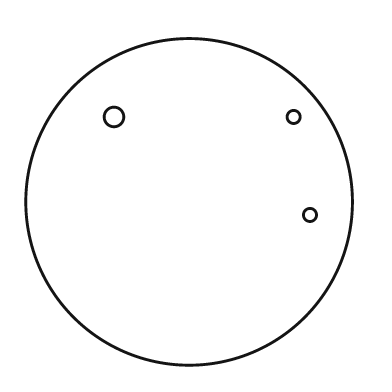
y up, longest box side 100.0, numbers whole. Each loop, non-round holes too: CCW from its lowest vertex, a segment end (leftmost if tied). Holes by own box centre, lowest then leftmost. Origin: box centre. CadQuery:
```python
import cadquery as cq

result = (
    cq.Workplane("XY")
    .moveTo(0.0, 0.0)
    .circle(50.0)
    .moveTo(37.0, -4.0)
    .circle(2.0)
    .moveTo(-23.0, 26.0)
    .circle(3.0)
    .moveTo(32.0, 26.0)
    .circle(2.0)
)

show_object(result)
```